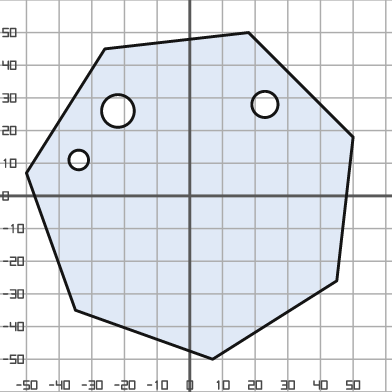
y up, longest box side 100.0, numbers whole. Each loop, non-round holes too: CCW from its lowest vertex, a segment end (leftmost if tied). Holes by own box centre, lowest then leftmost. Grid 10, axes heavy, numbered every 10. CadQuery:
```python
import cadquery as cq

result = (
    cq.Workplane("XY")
    .moveTo(7.0, -50.0)
    .lineTo(45.0, -26.0)
    .lineTo(50.0, 18.0)
    .lineTo(18.0, 50.0)
    .lineTo(-26.0, 45.0)
    .lineTo(-50.0, 7.0)
    .lineTo(-35.0, -35.0)
    .close()
    .moveTo(-34.0, 11.0)
    .circle(3.0)
    .moveTo(-22.0, 26.0)
    .circle(5.0)
    .moveTo(23.0, 28.0)
    .circle(4.0)
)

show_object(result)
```